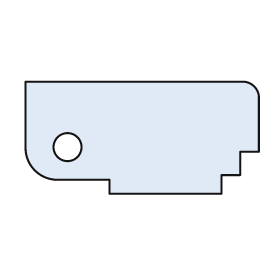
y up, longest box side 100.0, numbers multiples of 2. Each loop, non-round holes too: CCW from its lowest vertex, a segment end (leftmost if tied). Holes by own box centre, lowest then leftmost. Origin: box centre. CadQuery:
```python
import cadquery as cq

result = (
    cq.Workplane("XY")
    .moveTo(-14.0, -24.0)
    .lineTo(34.0, -24.0)
    .lineTo(34.0, -16.0)
    .lineTo(42.0, -16.0)
    .lineTo(42.0, -6.0)
    .lineTo(50.0, -6.0)
    .lineTo(50.0, 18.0)
    .threePointArc((48.0, 22.0), (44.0, 24.0))
    .lineTo(-50.0, 24.0)
    .lineTo(-50.0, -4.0)
    .threePointArc((-46.0, -14.0), (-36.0, -18.0))
    .lineTo(-14.0, -18.0)
    .close()
    .moveTo(-32.0, -4.0)
    .circle(6.0)
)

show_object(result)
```